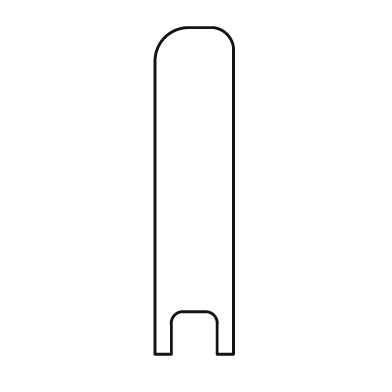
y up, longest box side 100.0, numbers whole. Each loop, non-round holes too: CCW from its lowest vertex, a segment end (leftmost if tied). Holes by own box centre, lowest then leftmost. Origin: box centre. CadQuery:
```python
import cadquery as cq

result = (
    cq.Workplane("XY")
    .moveTo(-12.0, -50.0)
    .lineTo(-7.0, -50.0)
    .lineTo(-7.0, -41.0)
    .threePointArc((-6.0, -38.0), (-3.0, -37.0))
    .lineTo(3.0, -37.0)
    .threePointArc((6.0, -38.0), (7.0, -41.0))
    .lineTo(7.0, -50.0)
    .lineTo(12.0, -50.0)
    .lineTo(12.0, 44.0)
    .threePointArc((10.0, 48.0), (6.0, 50.0))
    .lineTo(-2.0, 50.0)
    .threePointArc((-9.0, 47.0), (-12.0, 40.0))
    .close()
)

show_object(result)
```